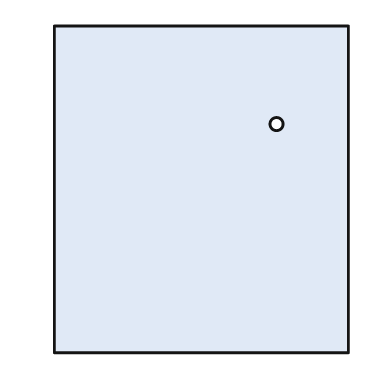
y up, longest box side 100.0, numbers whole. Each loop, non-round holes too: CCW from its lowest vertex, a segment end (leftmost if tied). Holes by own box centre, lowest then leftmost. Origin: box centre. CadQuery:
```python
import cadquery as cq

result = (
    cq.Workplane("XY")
    .moveTo(-45.0, -50.0)
    .lineTo(45.0, -50.0)
    .lineTo(45.0, 50.0)
    .lineTo(-45.0, 50.0)
    .close()
    .moveTo(23.0, 20.0)
    .circle(2.0)
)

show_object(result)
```